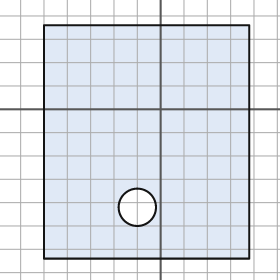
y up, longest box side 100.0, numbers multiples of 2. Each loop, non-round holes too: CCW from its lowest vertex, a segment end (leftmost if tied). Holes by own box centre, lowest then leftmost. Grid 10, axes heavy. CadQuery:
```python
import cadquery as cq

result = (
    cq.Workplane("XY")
    .moveTo(-50.0, -64.0)
    .lineTo(38.0, -64.0)
    .lineTo(38.0, 36.0)
    .lineTo(-50.0, 36.0)
    .close()
    .moveTo(-10.0, -42.0)
    .circle(8.0)
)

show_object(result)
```